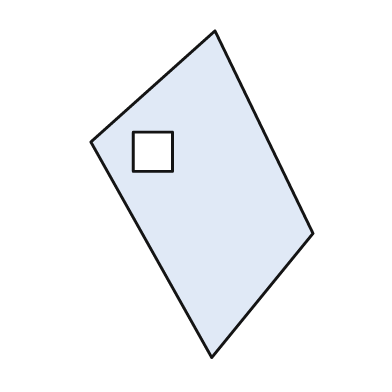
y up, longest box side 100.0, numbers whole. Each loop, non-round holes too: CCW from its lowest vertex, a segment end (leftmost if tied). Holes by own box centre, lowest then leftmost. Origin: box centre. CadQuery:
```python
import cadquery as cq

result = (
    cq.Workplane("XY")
    .moveTo(3.0, -50.0)
    .lineTo(34.0, -12.0)
    .lineTo(4.0, 50.0)
    .lineTo(-34.0, 16.0)
    .close()
    .moveTo(-21.0, 7.0)
    .lineTo(-9.0, 7.0)
    .lineTo(-9.0, 19.0)
    .lineTo(-21.0, 19.0)
    .close()
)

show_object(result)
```